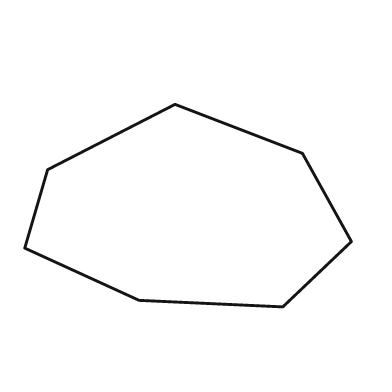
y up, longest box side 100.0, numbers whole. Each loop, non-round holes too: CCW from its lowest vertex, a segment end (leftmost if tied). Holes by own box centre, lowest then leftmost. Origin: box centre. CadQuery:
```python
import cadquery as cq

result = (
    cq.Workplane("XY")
    .moveTo(29.0, -31.0)
    .lineTo(50.0, -11.0)
    .lineTo(35.0, 16.0)
    .lineTo(-4.0, 31.0)
    .lineTo(-43.0, 11.0)
    .lineTo(-50.0, -13.0)
    .lineTo(-15.0, -29.0)
    .close()
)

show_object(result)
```